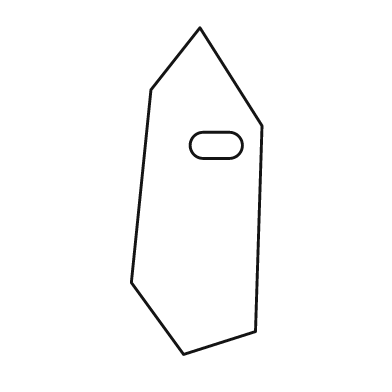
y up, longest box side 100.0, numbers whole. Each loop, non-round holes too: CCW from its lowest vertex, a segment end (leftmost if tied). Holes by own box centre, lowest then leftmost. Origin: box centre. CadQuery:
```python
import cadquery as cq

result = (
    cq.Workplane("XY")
    .moveTo(-4.0, -50.0)
    .lineTo(18.0, -43.0)
    .lineTo(20.0, 20.0)
    .lineTo(1.0, 50.0)
    .lineTo(-14.0, 31.0)
    .lineTo(-20.0, -28.0)
    .close()
    .moveTo(2.0, 10.0)
    .lineTo(10.0, 10.0)
    .threePointArc((14.0, 14.0), (10.0, 18.0))
    .lineTo(2.0, 18.0)
    .threePointArc((-2.0, 14.0), (2.0, 10.0))
    .close()
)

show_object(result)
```